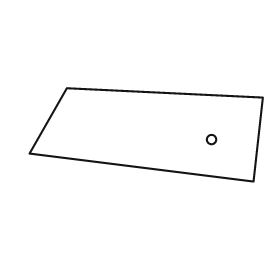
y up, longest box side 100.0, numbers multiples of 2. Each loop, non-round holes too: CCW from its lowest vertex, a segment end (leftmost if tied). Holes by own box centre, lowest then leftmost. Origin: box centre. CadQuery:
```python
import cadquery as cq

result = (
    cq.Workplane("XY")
    .moveTo(46.0, -20.0)
    .lineTo(50.0, 16.0)
    .lineTo(-34.0, 20.0)
    .lineTo(-50.0, -8.0)
    .close()
    .moveTo(28.0, -2.0)
    .circle(2.0)
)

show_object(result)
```